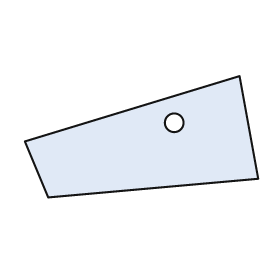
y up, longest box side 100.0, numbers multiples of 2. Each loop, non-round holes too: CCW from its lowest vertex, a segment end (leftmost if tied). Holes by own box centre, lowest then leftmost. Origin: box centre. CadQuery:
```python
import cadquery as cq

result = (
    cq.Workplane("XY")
    .moveTo(-40.0, -26.0)
    .lineTo(50.0, -18.0)
    .lineTo(42.0, 26.0)
    .lineTo(-50.0, -2.0)
    .close()
    .moveTo(14.0, 6.0)
    .circle(4.0)
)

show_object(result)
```